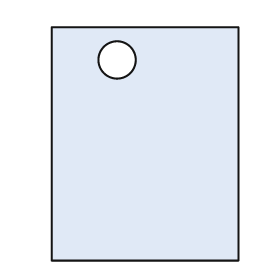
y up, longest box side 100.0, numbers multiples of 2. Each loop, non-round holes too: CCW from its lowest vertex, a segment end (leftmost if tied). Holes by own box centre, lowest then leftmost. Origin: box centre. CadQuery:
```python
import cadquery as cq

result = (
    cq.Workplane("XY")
    .moveTo(-40.0, -50.0)
    .lineTo(40.0, -50.0)
    .lineTo(40.0, 50.0)
    .lineTo(-40.0, 50.0)
    .close()
    .moveTo(-12.0, 36.0)
    .circle(8.0)
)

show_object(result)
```